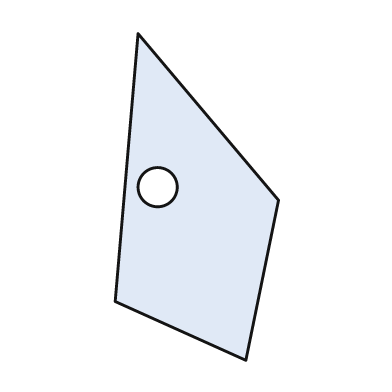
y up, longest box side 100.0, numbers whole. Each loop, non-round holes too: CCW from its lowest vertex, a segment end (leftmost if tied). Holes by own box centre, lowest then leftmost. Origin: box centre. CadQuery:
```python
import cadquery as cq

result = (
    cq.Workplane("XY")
    .moveTo(15.0, -50.0)
    .lineTo(25.0, -1.0)
    .lineTo(-18.0, 50.0)
    .lineTo(-25.0, -32.0)
    .close()
    .moveTo(-12.0, 3.0)
    .circle(6.0)
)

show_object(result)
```